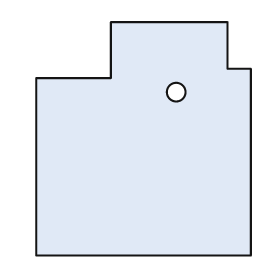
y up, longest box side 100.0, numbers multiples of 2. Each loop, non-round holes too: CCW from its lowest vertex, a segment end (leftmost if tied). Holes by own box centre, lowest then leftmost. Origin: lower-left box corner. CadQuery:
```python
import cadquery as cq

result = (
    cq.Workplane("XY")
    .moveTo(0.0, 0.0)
    .lineTo(92.0, 0.0)
    .lineTo(92.0, 80.0)
    .lineTo(82.0, 80.0)
    .lineTo(82.0, 100.0)
    .lineTo(32.0, 100.0)
    .lineTo(32.0, 76.0)
    .lineTo(0.0, 76.0)
    .close()
    .moveTo(60.0, 70.0)
    .circle(4.0)
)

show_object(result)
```